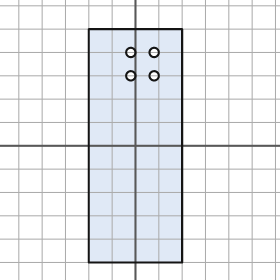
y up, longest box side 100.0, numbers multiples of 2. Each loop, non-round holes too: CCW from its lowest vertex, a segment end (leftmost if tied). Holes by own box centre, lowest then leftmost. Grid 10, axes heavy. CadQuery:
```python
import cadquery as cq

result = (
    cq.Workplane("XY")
    .moveTo(-20.0, -50.0)
    .lineTo(20.0, -50.0)
    .lineTo(20.0, 50.0)
    .lineTo(-20.0, 50.0)
    .close()
    .moveTo(-2.0, 30.0)
    .circle(2.0)
    .moveTo(8.0, 30.0)
    .circle(2.0)
    .moveTo(-2.0, 40.0)
    .circle(2.0)
    .moveTo(8.0, 40.0)
    .circle(2.0)
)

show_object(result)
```